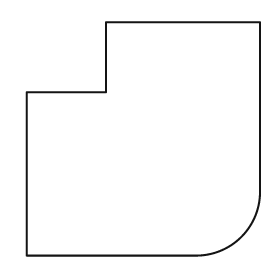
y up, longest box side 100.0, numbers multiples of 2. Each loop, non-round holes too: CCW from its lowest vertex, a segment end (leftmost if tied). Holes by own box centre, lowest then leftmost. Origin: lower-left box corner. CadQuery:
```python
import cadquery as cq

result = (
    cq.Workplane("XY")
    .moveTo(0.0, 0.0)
    .lineTo(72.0, 0.0)
    .threePointArc((92.0, 8.0), (100.0, 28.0))
    .lineTo(100.0, 100.0)
    .lineTo(34.0, 100.0)
    .lineTo(34.0, 70.0)
    .lineTo(0.0, 70.0)
    .close()
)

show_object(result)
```